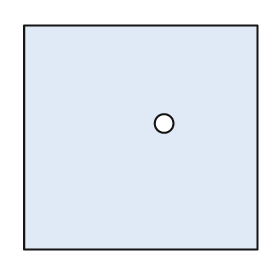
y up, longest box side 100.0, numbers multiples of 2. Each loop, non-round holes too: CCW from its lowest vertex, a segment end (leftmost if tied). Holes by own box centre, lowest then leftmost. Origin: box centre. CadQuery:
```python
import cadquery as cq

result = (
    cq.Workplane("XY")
    .moveTo(-50.0, -48.0)
    .lineTo(50.0, -48.0)
    .lineTo(50.0, 48.0)
    .lineTo(-50.0, 48.0)
    .close()
    .moveTo(10.0, 6.0)
    .circle(4.0)
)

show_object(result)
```